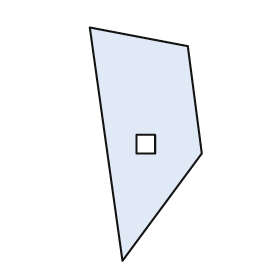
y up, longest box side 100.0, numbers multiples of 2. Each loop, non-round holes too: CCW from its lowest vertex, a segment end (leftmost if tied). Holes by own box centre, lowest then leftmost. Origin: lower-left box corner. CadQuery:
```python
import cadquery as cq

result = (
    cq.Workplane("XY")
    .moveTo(14.0, 0.0)
    .lineTo(48.0, 46.0)
    .lineTo(42.0, 92.0)
    .lineTo(0.0, 100.0)
    .close()
    .moveTo(20.0, 46.0)
    .lineTo(28.0, 46.0)
    .lineTo(28.0, 54.0)
    .lineTo(20.0, 54.0)
    .close()
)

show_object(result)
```